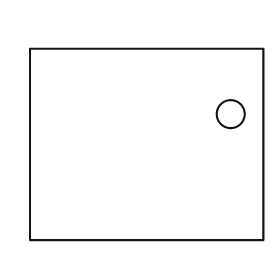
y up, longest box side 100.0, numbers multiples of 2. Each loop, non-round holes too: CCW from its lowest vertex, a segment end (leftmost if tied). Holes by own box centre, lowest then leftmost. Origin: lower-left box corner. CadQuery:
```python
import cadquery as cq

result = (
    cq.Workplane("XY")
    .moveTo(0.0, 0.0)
    .lineTo(100.0, 0.0)
    .lineTo(100.0, 82.0)
    .lineTo(0.0, 82.0)
    .close()
    .moveTo(86.0, 54.0)
    .circle(6.0)
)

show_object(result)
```